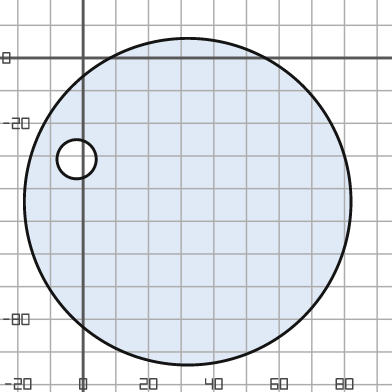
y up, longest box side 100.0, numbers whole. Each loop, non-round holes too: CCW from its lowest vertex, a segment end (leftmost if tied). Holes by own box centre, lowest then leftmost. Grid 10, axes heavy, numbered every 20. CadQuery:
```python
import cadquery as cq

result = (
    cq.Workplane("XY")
    .moveTo(32.0, -44.0)
    .circle(50.0)
    .moveTo(-2.0, -31.0)
    .circle(6.0)
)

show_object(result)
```